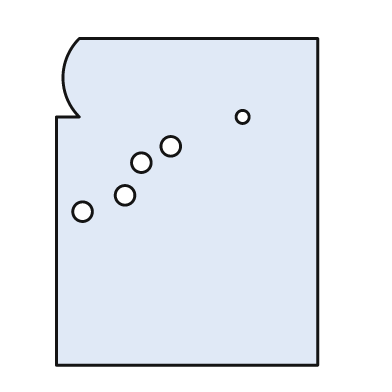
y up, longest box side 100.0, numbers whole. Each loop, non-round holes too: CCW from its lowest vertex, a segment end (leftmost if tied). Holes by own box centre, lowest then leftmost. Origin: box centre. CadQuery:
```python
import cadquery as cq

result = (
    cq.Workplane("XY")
    .moveTo(-40.0, -50.0)
    .lineTo(40.0, -50.0)
    .lineTo(40.0, 50.0)
    .lineTo(-33.0, 50.0)
    .threePointArc((-38.0, 38.0), (-33.0, 26.0))
    .lineTo(-40.0, 26.0)
    .close()
    .moveTo(-32.0, -3.0)
    .circle(3.0)
    .moveTo(-19.0, 2.0)
    .circle(3.0)
    .moveTo(-14.0, 12.0)
    .circle(3.0)
    .moveTo(-5.0, 17.0)
    .circle(3.0)
    .moveTo(17.0, 26.0)
    .circle(2.0)
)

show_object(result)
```